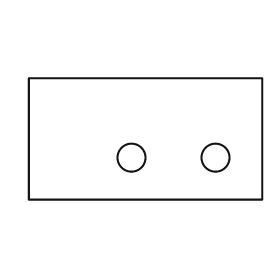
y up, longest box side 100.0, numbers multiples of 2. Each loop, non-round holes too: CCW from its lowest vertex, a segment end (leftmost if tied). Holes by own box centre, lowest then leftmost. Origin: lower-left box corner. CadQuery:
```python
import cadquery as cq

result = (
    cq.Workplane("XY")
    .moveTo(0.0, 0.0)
    .lineTo(100.0, 0.0)
    .lineTo(100.0, 52.0)
    .lineTo(0.0, 52.0)
    .close()
    .moveTo(44.0, 18.0)
    .circle(6.0)
    .moveTo(80.0, 18.0)
    .circle(6.0)
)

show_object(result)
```